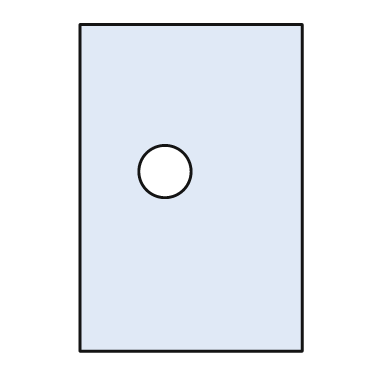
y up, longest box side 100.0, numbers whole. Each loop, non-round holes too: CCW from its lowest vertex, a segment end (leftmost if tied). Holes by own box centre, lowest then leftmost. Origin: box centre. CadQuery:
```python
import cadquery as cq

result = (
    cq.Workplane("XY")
    .moveTo(-34.0, -50.0)
    .lineTo(34.0, -50.0)
    .lineTo(34.0, 50.0)
    .lineTo(-34.0, 50.0)
    .close()
    .moveTo(-8.0, 5.0)
    .circle(8.0)
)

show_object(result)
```